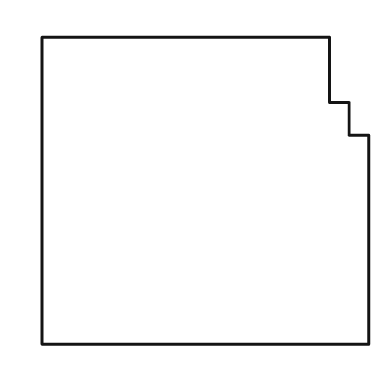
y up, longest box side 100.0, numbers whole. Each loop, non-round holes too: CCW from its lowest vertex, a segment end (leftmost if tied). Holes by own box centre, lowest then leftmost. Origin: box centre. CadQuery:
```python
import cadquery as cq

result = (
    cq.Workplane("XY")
    .moveTo(-50.0, -47.0)
    .lineTo(50.0, -47.0)
    .lineTo(50.0, 17.0)
    .lineTo(44.0, 17.0)
    .lineTo(44.0, 27.0)
    .lineTo(38.0, 27.0)
    .lineTo(38.0, 47.0)
    .lineTo(-50.0, 47.0)
    .close()
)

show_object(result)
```